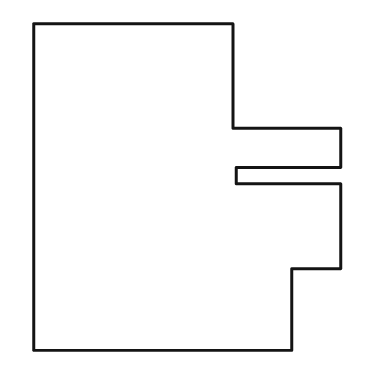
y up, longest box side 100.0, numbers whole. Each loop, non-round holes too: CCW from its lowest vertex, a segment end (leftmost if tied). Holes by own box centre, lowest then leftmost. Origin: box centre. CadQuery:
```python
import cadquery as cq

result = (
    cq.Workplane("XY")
    .moveTo(-47.0, -50.0)
    .lineTo(32.0, -50.0)
    .lineTo(32.0, -25.0)
    .lineTo(47.0, -25.0)
    .lineTo(47.0, 1.0)
    .lineTo(15.0, 1.0)
    .lineTo(15.0, 6.0)
    .lineTo(47.0, 6.0)
    .lineTo(47.0, 18.0)
    .lineTo(14.0, 18.0)
    .lineTo(14.0, 50.0)
    .lineTo(-47.0, 50.0)
    .close()
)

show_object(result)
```